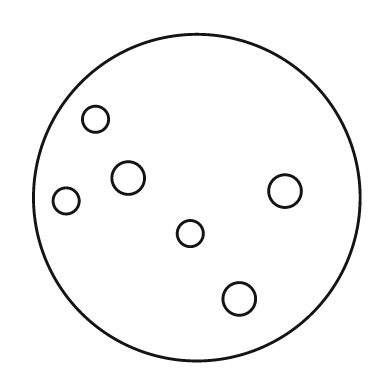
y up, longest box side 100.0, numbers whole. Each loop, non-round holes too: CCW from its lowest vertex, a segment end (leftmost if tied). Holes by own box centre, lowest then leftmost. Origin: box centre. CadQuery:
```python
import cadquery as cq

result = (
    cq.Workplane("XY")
    .moveTo(0.0, 0.0)
    .circle(50.0)
    .moveTo(13.0, -31.0)
    .circle(5.0)
    .moveTo(-2.0, -11.0)
    .circle(4.0)
    .moveTo(-40.0, -1.0)
    .circle(4.0)
    .moveTo(27.0, 2.0)
    .circle(5.0)
    .moveTo(-21.0, 6.0)
    .circle(5.0)
    .moveTo(-31.0, 24.0)
    .circle(4.0)
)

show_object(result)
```